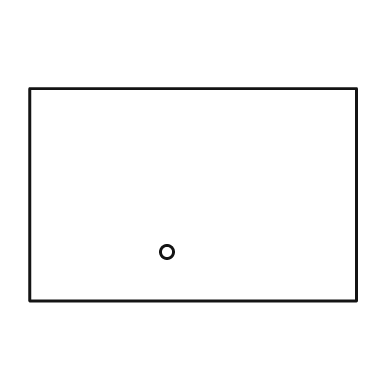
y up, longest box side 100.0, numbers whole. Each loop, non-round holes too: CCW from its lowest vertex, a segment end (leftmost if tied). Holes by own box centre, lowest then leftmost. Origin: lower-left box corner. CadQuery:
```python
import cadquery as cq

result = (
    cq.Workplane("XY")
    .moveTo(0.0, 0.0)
    .lineTo(100.0, 0.0)
    .lineTo(100.0, 65.0)
    .lineTo(0.0, 65.0)
    .close()
    .moveTo(42.0, 15.0)
    .circle(2.0)
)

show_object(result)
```